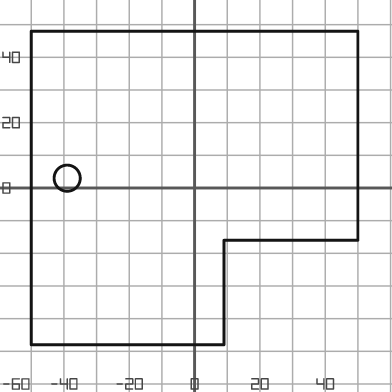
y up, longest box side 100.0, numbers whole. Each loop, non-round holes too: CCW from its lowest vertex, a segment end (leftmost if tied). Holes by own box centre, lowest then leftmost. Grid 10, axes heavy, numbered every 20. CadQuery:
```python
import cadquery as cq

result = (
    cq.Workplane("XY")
    .moveTo(-50.0, -48.0)
    .lineTo(9.0, -48.0)
    .lineTo(9.0, -16.0)
    .lineTo(50.0, -16.0)
    .lineTo(50.0, 48.0)
    .lineTo(-50.0, 48.0)
    .close()
    .moveTo(-39.0, 3.0)
    .circle(4.0)
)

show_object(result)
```